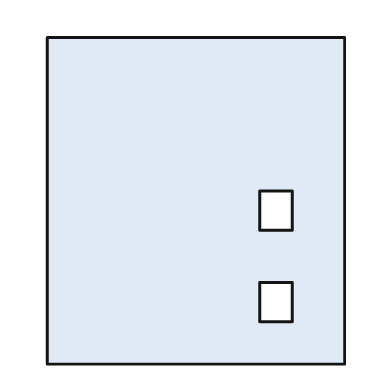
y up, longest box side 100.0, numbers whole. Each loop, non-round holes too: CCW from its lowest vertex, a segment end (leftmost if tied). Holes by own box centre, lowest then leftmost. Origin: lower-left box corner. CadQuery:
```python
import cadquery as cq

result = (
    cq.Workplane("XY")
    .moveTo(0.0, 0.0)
    .lineTo(91.0, 0.0)
    .lineTo(91.0, 100.0)
    .lineTo(0.0, 100.0)
    .close()
    .moveTo(65.0, 13.0)
    .lineTo(75.0, 13.0)
    .lineTo(75.0, 25.0)
    .lineTo(65.0, 25.0)
    .close()
    .moveTo(65.0, 41.0)
    .lineTo(75.0, 41.0)
    .lineTo(75.0, 53.0)
    .lineTo(65.0, 53.0)
    .close()
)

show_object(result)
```